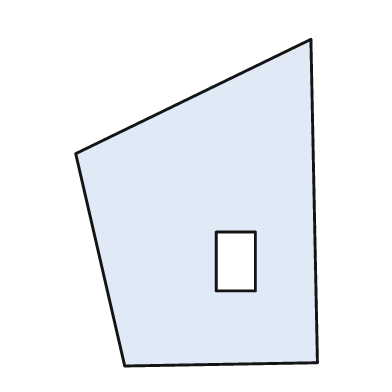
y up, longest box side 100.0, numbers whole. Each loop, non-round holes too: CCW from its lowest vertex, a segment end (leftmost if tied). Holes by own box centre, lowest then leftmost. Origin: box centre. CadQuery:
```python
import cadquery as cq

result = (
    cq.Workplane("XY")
    .moveTo(-22.0, -50.0)
    .lineTo(37.0, -49.0)
    .lineTo(35.0, 50.0)
    .lineTo(-37.0, 15.0)
    .close()
    .moveTo(6.0, -27.0)
    .lineTo(18.0, -27.0)
    .lineTo(18.0, -9.0)
    .lineTo(6.0, -9.0)
    .close()
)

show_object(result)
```